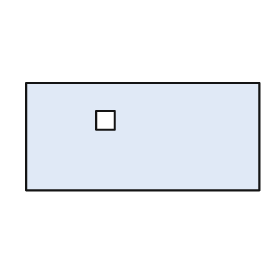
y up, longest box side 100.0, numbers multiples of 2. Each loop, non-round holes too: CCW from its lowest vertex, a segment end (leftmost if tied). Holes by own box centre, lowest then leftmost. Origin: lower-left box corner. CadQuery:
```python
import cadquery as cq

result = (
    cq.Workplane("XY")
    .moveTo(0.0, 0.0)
    .lineTo(100.0, 0.0)
    .lineTo(100.0, 46.0)
    .lineTo(0.0, 46.0)
    .close()
    .moveTo(30.0, 26.0)
    .lineTo(38.0, 26.0)
    .lineTo(38.0, 34.0)
    .lineTo(30.0, 34.0)
    .close()
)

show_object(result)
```